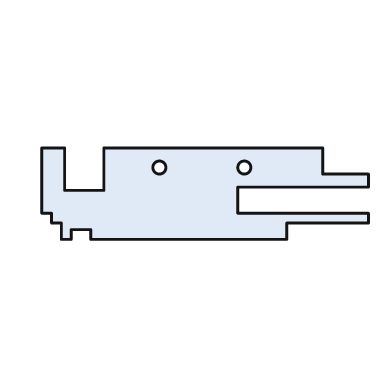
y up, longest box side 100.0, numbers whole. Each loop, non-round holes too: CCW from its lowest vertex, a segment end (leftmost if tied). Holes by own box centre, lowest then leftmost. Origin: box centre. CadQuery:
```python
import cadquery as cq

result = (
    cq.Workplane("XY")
    .moveTo(-44.0, -14.0)
    .lineTo(-41.0, -14.0)
    .lineTo(-41.0, -11.0)
    .lineTo(-35.0, -11.0)
    .lineTo(-35.0, -14.0)
    .lineTo(25.0, -14.0)
    .lineTo(25.0, -9.0)
    .lineTo(50.0, -9.0)
    .lineTo(50.0, -6.0)
    .lineTo(10.0, -6.0)
    .lineTo(10.0, 2.0)
    .lineTo(50.0, 2.0)
    .lineTo(50.0, 6.0)
    .lineTo(36.0, 6.0)
    .lineTo(36.0, 14.0)
    .lineTo(-31.0, 14.0)
    .lineTo(-31.0, 1.0)
    .lineTo(-43.0, 1.0)
    .lineTo(-43.0, 14.0)
    .lineTo(-50.0, 14.0)
    .lineTo(-50.0, -6.0)
    .lineTo(-47.0, -6.0)
    .lineTo(-47.0, -9.0)
    .lineTo(-44.0, -9.0)
    .close()
    .moveTo(-14.0, 8.0)
    .circle(2.0)
    .moveTo(12.0, 8.0)
    .circle(2.0)
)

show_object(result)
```